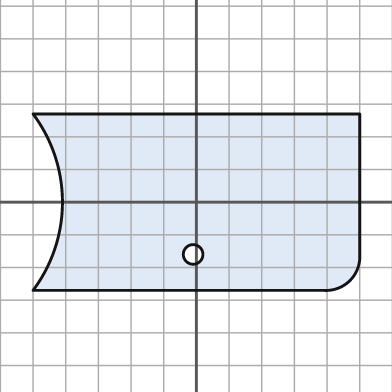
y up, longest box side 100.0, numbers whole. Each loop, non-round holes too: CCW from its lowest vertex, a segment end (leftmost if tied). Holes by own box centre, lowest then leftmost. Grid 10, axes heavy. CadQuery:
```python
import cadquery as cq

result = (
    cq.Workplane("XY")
    .moveTo(-50.0, -27.0)
    .lineTo(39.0, -27.0)
    .threePointArc((47.0, -24.0), (50.0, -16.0))
    .lineTo(50.0, 27.0)
    .lineTo(-50.0, 27.0)
    .threePointArc((-41.0, 0.0), (-50.0, -27.0))
    .close()
    .moveTo(-1.0, -16.0)
    .circle(3.0)
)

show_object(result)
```